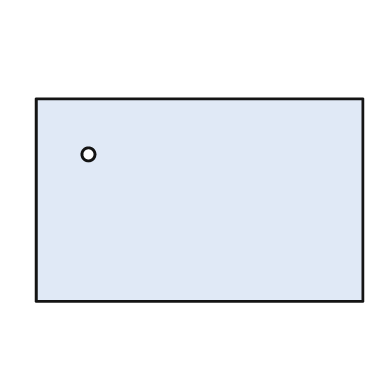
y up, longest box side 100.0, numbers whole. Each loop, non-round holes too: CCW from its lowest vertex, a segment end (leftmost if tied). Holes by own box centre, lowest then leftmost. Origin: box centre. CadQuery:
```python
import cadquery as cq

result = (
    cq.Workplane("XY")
    .moveTo(-50.0, -31.0)
    .lineTo(50.0, -31.0)
    .lineTo(50.0, 31.0)
    .lineTo(-50.0, 31.0)
    .close()
    .moveTo(-34.0, 14.0)
    .circle(2.0)
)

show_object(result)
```